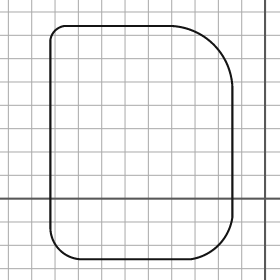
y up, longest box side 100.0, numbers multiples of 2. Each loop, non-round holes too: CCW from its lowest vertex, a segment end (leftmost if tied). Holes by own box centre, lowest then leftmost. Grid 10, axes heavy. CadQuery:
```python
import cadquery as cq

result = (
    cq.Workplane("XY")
    .moveTo(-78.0, -26.0)
    .lineTo(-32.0, -26.0)
    .threePointArc((-20.0, -20.0), (-14.0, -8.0))
    .lineTo(-14.0, 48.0)
    .threePointArc((-22.0, 66.0), (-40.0, 74.0))
    .lineTo(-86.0, 74.0)
    .threePointArc((-90.0, 72.0), (-92.0, 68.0))
    .lineTo(-92.0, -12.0)
    .threePointArc((-88.0, -22.0), (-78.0, -26.0))
    .close()
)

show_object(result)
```